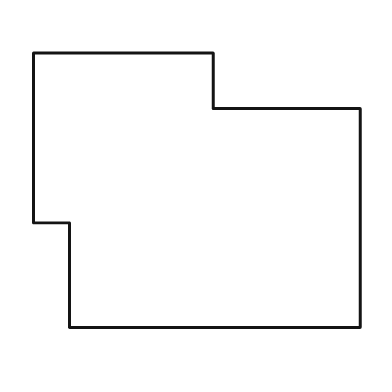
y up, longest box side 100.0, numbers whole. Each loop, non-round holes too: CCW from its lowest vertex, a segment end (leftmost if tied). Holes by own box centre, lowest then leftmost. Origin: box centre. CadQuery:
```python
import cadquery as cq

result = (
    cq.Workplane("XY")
    .moveTo(-39.0, -42.0)
    .lineTo(50.0, -42.0)
    .lineTo(50.0, 25.0)
    .lineTo(5.0, 25.0)
    .lineTo(5.0, 42.0)
    .lineTo(-50.0, 42.0)
    .lineTo(-50.0, -10.0)
    .lineTo(-39.0, -10.0)
    .close()
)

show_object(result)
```